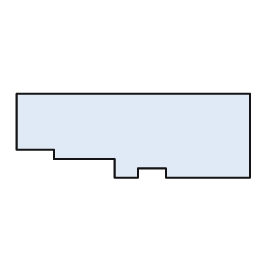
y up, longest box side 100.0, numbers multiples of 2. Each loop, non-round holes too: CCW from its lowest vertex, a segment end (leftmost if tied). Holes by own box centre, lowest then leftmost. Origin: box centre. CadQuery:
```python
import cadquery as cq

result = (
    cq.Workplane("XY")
    .moveTo(-8.0, -18.0)
    .lineTo(2.0, -18.0)
    .lineTo(2.0, -14.0)
    .lineTo(14.0, -14.0)
    .lineTo(14.0, -18.0)
    .lineTo(50.0, -18.0)
    .lineTo(50.0, 18.0)
    .lineTo(-50.0, 18.0)
    .lineTo(-50.0, -6.0)
    .lineTo(-34.0, -6.0)
    .lineTo(-34.0, -10.0)
    .lineTo(-8.0, -10.0)
    .close()
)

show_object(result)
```